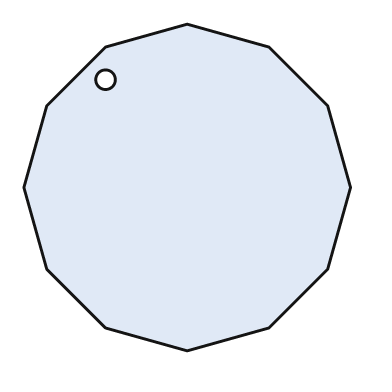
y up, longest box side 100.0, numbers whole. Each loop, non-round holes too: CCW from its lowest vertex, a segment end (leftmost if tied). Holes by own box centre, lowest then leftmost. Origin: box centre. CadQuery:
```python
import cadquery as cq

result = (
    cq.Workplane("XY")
    .moveTo(0.0, -50.0)
    .lineTo(25.0, -43.0)
    .lineTo(43.0, -25.0)
    .lineTo(50.0, 0.0)
    .lineTo(43.0, 25.0)
    .lineTo(25.0, 43.0)
    .lineTo(0.0, 50.0)
    .lineTo(-25.0, 43.0)
    .lineTo(-43.0, 25.0)
    .lineTo(-50.0, 0.0)
    .lineTo(-43.0, -25.0)
    .lineTo(-25.0, -43.0)
    .close()
    .moveTo(-25.0, 33.0)
    .circle(3.0)
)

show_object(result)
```